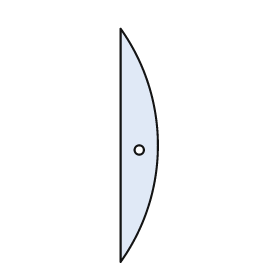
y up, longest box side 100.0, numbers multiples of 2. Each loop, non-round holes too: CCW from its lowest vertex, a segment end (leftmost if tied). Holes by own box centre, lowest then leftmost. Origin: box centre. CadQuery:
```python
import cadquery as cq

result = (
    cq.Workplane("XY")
    .moveTo(-8.0, -50.0)
    .threePointArc((8.0, 0.0), (-8.0, 50.0))
    .close()
    .moveTo(0.0, -2.0)
    .circle(2.0)
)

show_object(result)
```